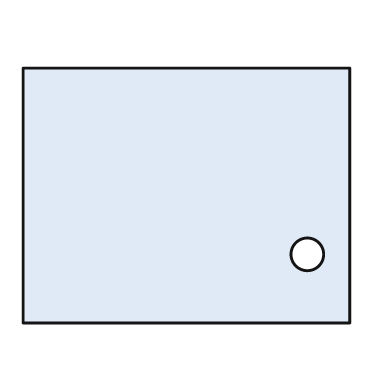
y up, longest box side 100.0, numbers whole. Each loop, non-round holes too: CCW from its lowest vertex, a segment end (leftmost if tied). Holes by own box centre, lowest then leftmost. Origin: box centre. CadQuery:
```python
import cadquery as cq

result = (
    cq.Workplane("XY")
    .moveTo(-50.0, -39.0)
    .lineTo(50.0, -39.0)
    .lineTo(50.0, 39.0)
    .lineTo(-50.0, 39.0)
    .close()
    .moveTo(37.0, -18.0)
    .circle(5.0)
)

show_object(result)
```